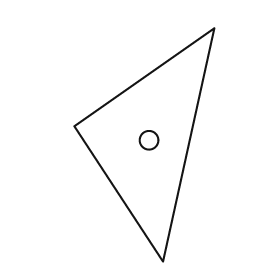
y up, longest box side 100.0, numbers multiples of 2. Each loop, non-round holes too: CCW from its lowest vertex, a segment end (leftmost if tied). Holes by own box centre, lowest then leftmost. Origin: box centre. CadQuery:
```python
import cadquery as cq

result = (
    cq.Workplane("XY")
    .moveTo(8.0, -50.0)
    .lineTo(30.0, 50.0)
    .lineTo(-30.0, 8.0)
    .close()
    .moveTo(2.0, 2.0)
    .circle(4.0)
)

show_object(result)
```